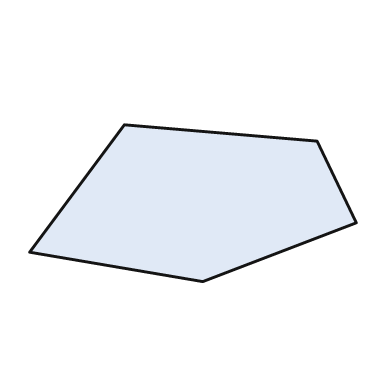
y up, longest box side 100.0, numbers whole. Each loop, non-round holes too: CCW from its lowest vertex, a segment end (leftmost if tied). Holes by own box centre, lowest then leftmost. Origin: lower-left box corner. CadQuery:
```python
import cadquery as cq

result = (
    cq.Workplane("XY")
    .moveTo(53.0, 0.0)
    .lineTo(100.0, 18.0)
    .lineTo(88.0, 43.0)
    .lineTo(29.0, 48.0)
    .lineTo(0.0, 9.0)
    .close()
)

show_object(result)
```